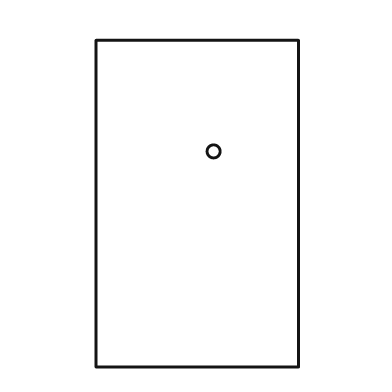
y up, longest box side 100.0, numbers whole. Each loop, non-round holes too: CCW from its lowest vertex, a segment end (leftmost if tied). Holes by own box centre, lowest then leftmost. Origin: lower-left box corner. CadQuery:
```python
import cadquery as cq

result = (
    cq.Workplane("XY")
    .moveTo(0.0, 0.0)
    .lineTo(62.0, 0.0)
    .lineTo(62.0, 100.0)
    .lineTo(0.0, 100.0)
    .close()
    .moveTo(36.0, 66.0)
    .circle(2.0)
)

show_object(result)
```